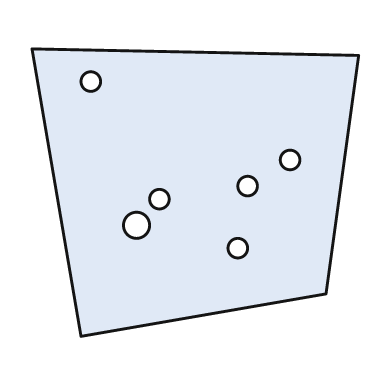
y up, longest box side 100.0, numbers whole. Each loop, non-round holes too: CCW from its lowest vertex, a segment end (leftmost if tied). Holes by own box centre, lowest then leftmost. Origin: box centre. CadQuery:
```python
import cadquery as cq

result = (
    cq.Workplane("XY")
    .moveTo(-35.0, -44.0)
    .lineTo(40.0, -31.0)
    .lineTo(50.0, 42.0)
    .lineTo(-50.0, 44.0)
    .close()
    .moveTo(13.0, -17.0)
    .circle(3.0)
    .moveTo(-18.0, -10.0)
    .circle(4.0)
    .moveTo(-11.0, -2.0)
    .circle(3.0)
    .moveTo(16.0, 2.0)
    .circle(3.0)
    .moveTo(29.0, 10.0)
    .circle(3.0)
    .moveTo(-32.0, 34.0)
    .circle(3.0)
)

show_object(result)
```